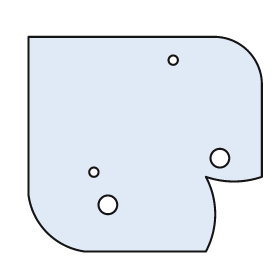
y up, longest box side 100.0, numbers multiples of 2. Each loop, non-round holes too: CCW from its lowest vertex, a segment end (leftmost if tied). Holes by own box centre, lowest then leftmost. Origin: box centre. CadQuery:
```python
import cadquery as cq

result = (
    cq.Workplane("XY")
    .moveTo(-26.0, -46.0)
    .lineTo(26.0, -46.0)
    .threePointArc((30.0, -30.0), (26.0, -14.0))
    .threePointArc((38.0, -16.0), (50.0, -14.0))
    .lineTo(50.0, 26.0)
    .threePointArc((44.0, 40.0), (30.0, 46.0))
    .lineTo(-50.0, 46.0)
    .lineTo(-50.0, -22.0)
    .threePointArc((-42.0, -38.0), (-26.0, -46.0))
    .close()
    .moveTo(-16.0, -26.0)
    .circle(4.0)
    .moveTo(-22.0, -12.0)
    .circle(2.0)
    .moveTo(32.0, -6.0)
    .circle(4.0)
    .moveTo(12.0, 36.0)
    .circle(2.0)
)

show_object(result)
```